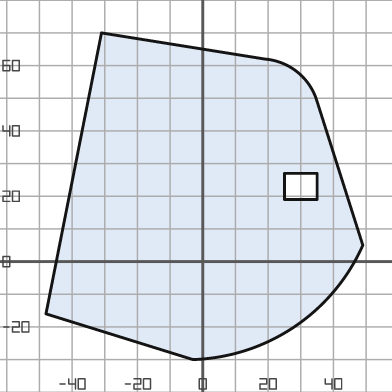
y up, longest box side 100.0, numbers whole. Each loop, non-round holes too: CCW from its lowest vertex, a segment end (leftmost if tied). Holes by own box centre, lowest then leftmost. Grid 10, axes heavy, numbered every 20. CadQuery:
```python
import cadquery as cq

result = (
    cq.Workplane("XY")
    .moveTo(-3.0, -30.0)
    .threePointArc((28.0, -20.0), (49.0, 5.0))
    .lineTo(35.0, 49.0)
    .threePointArc((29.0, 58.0), (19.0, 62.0))
    .lineTo(-31.0, 70.0)
    .lineTo(-48.0, -16.0)
    .close()
    .moveTo(25.0, 19.0)
    .lineTo(35.0, 19.0)
    .lineTo(35.0, 27.0)
    .lineTo(25.0, 27.0)
    .close()
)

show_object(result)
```